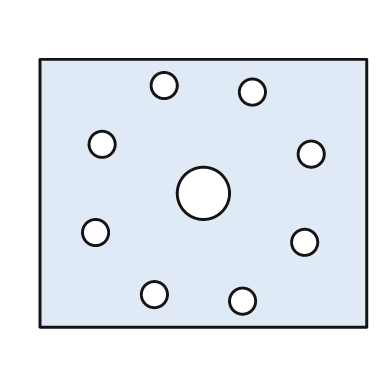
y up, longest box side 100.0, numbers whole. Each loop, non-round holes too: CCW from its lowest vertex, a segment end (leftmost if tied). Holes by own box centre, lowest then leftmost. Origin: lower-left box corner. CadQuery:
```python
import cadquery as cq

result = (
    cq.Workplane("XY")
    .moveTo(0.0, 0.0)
    .lineTo(100.0, 0.0)
    .lineTo(100.0, 82.0)
    .lineTo(0.0, 82.0)
    .close()
    .moveTo(62.0, 8.0)
    .circle(4.0)
    .moveTo(35.0, 10.0)
    .circle(4.0)
    .moveTo(81.0, 26.0)
    .circle(4.0)
    .moveTo(17.0, 29.0)
    .circle(4.0)
    .moveTo(50.0, 41.0)
    .circle(8.0)
    .moveTo(83.0, 53.0)
    .circle(4.0)
    .moveTo(19.0, 56.0)
    .circle(4.0)
    .moveTo(65.0, 72.0)
    .circle(4.0)
    .moveTo(38.0, 74.0)
    .circle(4.0)
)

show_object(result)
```